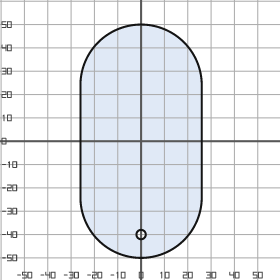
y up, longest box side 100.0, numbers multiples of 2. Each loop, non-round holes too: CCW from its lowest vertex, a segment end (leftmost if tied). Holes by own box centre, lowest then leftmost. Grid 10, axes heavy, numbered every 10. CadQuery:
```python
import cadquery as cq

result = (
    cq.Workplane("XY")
    .moveTo(-26.0, -24.0)
    .threePointArc((0.0, -50.0), (26.0, -24.0))
    .lineTo(26.0, 24.0)
    .threePointArc((0.0, 50.0), (-26.0, 24.0))
    .close()
    .moveTo(0.0, -40.0)
    .circle(2.0)
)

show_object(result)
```